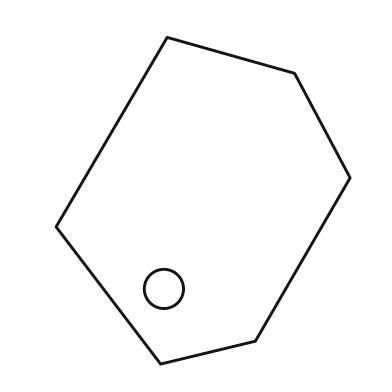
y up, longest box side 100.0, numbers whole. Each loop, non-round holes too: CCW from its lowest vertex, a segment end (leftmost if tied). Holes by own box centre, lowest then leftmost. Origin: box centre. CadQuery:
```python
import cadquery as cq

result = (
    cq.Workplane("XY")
    .moveTo(-13.0, -50.0)
    .lineTo(16.0, -43.0)
    .lineTo(45.0, 7.0)
    .lineTo(28.0, 39.0)
    .lineTo(-11.0, 50.0)
    .lineTo(-45.0, -8.0)
    .close()
    .moveTo(-12.0, -27.0)
    .circle(6.0)
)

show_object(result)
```